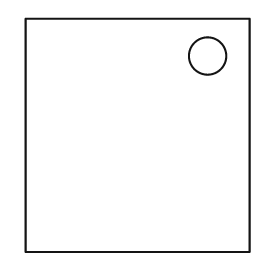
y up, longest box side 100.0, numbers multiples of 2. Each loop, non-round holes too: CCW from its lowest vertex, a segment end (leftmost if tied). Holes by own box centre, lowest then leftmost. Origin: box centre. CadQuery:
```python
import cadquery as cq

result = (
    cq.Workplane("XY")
    .moveTo(-48.0, -50.0)
    .lineTo(48.0, -50.0)
    .lineTo(48.0, 50.0)
    .lineTo(-48.0, 50.0)
    .close()
    .moveTo(30.0, 34.0)
    .circle(8.0)
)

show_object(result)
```